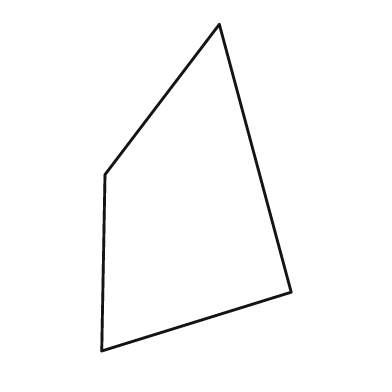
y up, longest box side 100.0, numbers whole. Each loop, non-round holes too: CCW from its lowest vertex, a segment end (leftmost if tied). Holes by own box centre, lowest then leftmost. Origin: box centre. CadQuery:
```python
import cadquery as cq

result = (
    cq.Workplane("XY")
    .moveTo(-29.0, -50.0)
    .lineTo(29.0, -32.0)
    .lineTo(7.0, 50.0)
    .lineTo(-28.0, 4.0)
    .close()
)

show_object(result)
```